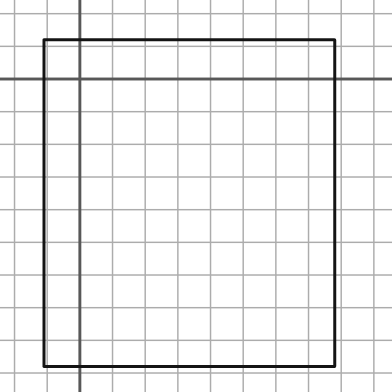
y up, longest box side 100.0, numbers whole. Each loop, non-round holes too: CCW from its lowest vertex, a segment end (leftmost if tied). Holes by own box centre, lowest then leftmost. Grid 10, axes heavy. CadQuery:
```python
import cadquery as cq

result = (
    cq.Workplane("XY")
    .moveTo(-11.0, -88.0)
    .lineTo(78.0, -88.0)
    .lineTo(78.0, 12.0)
    .lineTo(-11.0, 12.0)
    .close()
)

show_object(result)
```